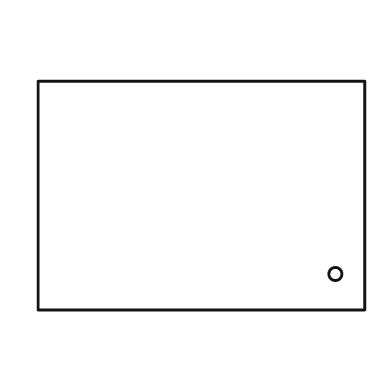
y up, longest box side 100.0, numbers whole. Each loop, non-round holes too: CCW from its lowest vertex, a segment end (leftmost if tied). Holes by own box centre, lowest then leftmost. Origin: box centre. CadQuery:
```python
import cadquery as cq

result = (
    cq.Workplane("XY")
    .moveTo(-50.0, -35.0)
    .lineTo(50.0, -35.0)
    .lineTo(50.0, 35.0)
    .lineTo(-50.0, 35.0)
    .close()
    .moveTo(41.0, -24.0)
    .circle(2.0)
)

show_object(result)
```